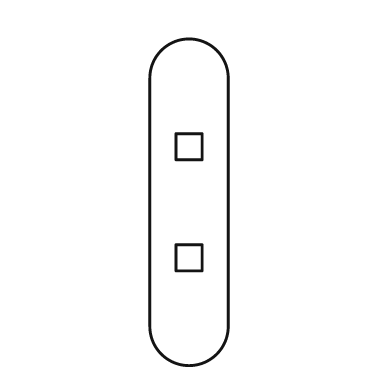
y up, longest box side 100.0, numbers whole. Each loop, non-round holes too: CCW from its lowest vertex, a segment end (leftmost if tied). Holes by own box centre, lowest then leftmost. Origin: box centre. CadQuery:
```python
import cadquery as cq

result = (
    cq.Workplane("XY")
    .moveTo(-12.0, -38.0)
    .threePointArc((0.0, -50.0), (12.0, -38.0))
    .lineTo(12.0, 38.0)
    .threePointArc((0.0, 50.0), (-12.0, 38.0))
    .close()
    .moveTo(-4.0, -21.0)
    .lineTo(4.0, -21.0)
    .lineTo(4.0, -13.0)
    .lineTo(-4.0, -13.0)
    .close()
    .moveTo(-4.0, 13.0)
    .lineTo(4.0, 13.0)
    .lineTo(4.0, 21.0)
    .lineTo(-4.0, 21.0)
    .close()
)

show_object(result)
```